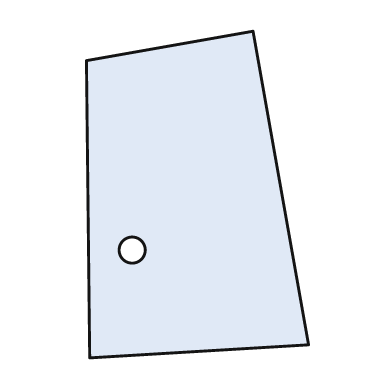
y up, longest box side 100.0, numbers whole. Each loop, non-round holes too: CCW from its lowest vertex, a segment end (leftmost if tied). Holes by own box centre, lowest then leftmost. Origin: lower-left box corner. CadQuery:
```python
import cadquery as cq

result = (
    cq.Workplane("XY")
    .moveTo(1.0, 0.0)
    .lineTo(68.0, 4.0)
    .lineTo(51.0, 100.0)
    .lineTo(0.0, 91.0)
    .close()
    .moveTo(14.0, 33.0)
    .circle(4.0)
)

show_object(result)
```